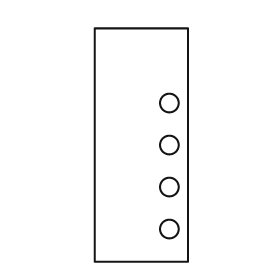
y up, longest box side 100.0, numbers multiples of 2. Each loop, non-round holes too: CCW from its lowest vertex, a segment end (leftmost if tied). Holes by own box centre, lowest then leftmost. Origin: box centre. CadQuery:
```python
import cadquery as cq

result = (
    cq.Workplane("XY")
    .moveTo(-20.0, -50.0)
    .lineTo(20.0, -50.0)
    .lineTo(20.0, 50.0)
    .lineTo(-20.0, 50.0)
    .close()
    .moveTo(12.0, -36.0)
    .circle(4.0)
    .moveTo(12.0, -18.0)
    .circle(4.0)
    .moveTo(12.0, 0.0)
    .circle(4.0)
    .moveTo(12.0, 18.0)
    .circle(4.0)
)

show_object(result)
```